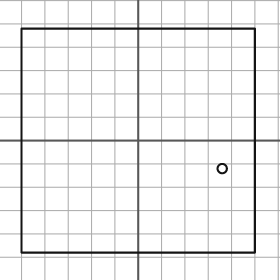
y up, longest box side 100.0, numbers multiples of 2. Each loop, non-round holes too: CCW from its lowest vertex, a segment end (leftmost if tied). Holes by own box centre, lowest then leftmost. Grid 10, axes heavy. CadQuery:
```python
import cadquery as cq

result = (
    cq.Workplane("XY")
    .moveTo(-50.0, -48.0)
    .lineTo(50.0, -48.0)
    .lineTo(50.0, 48.0)
    .lineTo(-50.0, 48.0)
    .close()
    .moveTo(36.0, -12.0)
    .circle(2.0)
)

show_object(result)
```